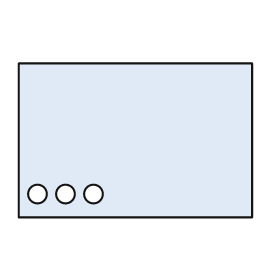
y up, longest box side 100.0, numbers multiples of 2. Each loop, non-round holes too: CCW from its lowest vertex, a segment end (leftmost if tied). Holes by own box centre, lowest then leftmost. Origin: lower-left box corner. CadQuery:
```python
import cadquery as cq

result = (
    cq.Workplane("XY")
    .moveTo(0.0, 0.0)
    .lineTo(100.0, 0.0)
    .lineTo(100.0, 66.0)
    .lineTo(0.0, 66.0)
    .close()
    .moveTo(8.0, 10.0)
    .circle(4.0)
    .moveTo(20.0, 10.0)
    .circle(4.0)
    .moveTo(32.0, 10.0)
    .circle(4.0)
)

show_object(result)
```